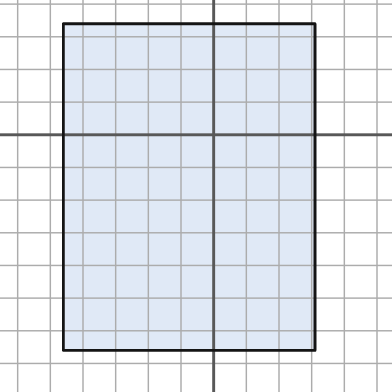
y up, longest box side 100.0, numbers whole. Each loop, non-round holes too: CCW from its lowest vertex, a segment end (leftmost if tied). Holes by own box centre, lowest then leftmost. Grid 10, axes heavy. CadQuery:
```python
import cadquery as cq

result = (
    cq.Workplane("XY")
    .moveTo(-46.0, -66.0)
    .lineTo(31.0, -66.0)
    .lineTo(31.0, 34.0)
    .lineTo(-46.0, 34.0)
    .close()
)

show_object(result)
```